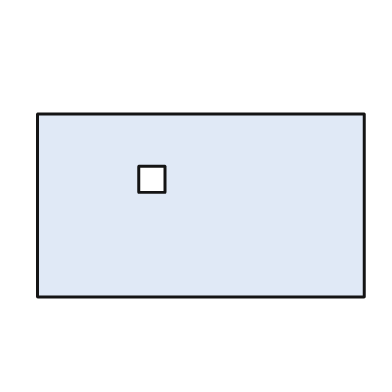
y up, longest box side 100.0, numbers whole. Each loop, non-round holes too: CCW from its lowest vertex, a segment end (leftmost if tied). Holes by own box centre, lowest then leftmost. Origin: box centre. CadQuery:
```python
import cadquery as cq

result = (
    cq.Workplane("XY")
    .moveTo(-50.0, -28.0)
    .lineTo(50.0, -28.0)
    .lineTo(50.0, 28.0)
    .lineTo(-50.0, 28.0)
    .close()
    .moveTo(-19.0, 4.0)
    .lineTo(-11.0, 4.0)
    .lineTo(-11.0, 12.0)
    .lineTo(-19.0, 12.0)
    .close()
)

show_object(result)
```